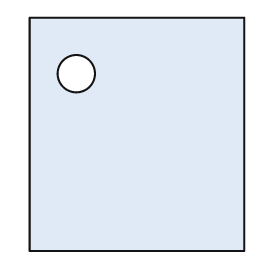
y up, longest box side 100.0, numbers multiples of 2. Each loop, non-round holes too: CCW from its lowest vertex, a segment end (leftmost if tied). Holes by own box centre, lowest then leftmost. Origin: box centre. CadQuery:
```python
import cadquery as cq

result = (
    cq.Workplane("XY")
    .moveTo(-46.0, -50.0)
    .lineTo(46.0, -50.0)
    .lineTo(46.0, 50.0)
    .lineTo(-46.0, 50.0)
    .close()
    .moveTo(-26.0, 26.0)
    .circle(8.0)
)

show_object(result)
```